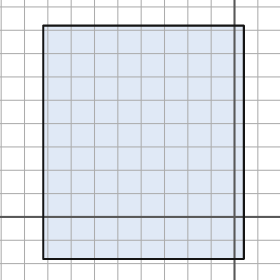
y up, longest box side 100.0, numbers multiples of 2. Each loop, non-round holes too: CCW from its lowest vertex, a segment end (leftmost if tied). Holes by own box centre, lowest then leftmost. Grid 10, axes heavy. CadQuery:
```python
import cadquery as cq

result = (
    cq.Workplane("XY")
    .moveTo(-82.0, -18.0)
    .lineTo(4.0, -18.0)
    .lineTo(4.0, 82.0)
    .lineTo(-82.0, 82.0)
    .close()
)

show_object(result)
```